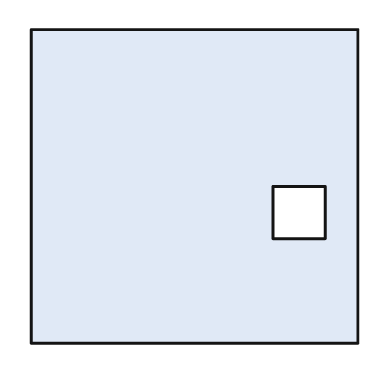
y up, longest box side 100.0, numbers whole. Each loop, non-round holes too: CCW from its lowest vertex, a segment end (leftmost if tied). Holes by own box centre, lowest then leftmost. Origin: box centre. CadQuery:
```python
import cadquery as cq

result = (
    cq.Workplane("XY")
    .moveTo(-50.0, -48.0)
    .lineTo(50.0, -48.0)
    .lineTo(50.0, 48.0)
    .lineTo(-50.0, 48.0)
    .close()
    .moveTo(24.0, -16.0)
    .lineTo(40.0, -16.0)
    .lineTo(40.0, 0.0)
    .lineTo(24.0, 0.0)
    .close()
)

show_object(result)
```